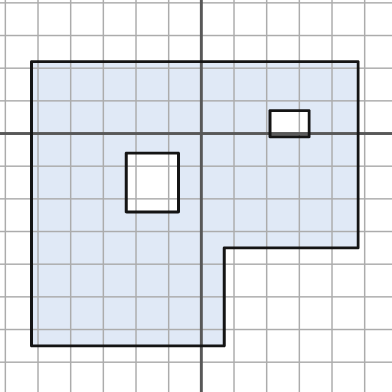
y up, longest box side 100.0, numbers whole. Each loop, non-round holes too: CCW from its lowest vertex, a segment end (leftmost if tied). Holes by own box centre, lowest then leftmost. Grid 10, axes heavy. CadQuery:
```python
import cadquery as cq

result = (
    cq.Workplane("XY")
    .moveTo(-52.0, -65.0)
    .lineTo(7.0, -65.0)
    .lineTo(7.0, -35.0)
    .lineTo(48.0, -35.0)
    .lineTo(48.0, 22.0)
    .lineTo(-52.0, 22.0)
    .close()
    .moveTo(-23.0, -24.0)
    .lineTo(-7.0, -24.0)
    .lineTo(-7.0, -6.0)
    .lineTo(-23.0, -6.0)
    .close()
    .moveTo(21.0, -1.0)
    .lineTo(33.0, -1.0)
    .lineTo(33.0, 7.0)
    .lineTo(21.0, 7.0)
    .close()
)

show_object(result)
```